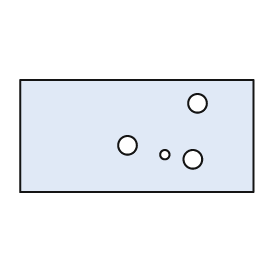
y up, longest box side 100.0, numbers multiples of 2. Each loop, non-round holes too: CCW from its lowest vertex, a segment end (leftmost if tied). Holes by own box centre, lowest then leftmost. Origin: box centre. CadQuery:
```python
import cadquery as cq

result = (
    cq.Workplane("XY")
    .moveTo(-50.0, -24.0)
    .lineTo(50.0, -24.0)
    .lineTo(50.0, 24.0)
    .lineTo(-50.0, 24.0)
    .close()
    .moveTo(24.0, -10.0)
    .circle(4.0)
    .moveTo(12.0, -8.0)
    .circle(2.0)
    .moveTo(-4.0, -4.0)
    .circle(4.0)
    .moveTo(26.0, 14.0)
    .circle(4.0)
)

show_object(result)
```